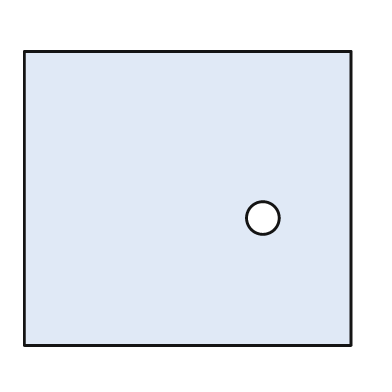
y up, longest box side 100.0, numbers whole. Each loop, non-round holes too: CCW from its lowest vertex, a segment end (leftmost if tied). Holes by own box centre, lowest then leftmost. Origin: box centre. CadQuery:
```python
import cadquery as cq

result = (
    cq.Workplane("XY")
    .moveTo(-50.0, -45.0)
    .lineTo(50.0, -45.0)
    .lineTo(50.0, 45.0)
    .lineTo(-50.0, 45.0)
    .close()
    .moveTo(23.0, -6.0)
    .circle(5.0)
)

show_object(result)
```